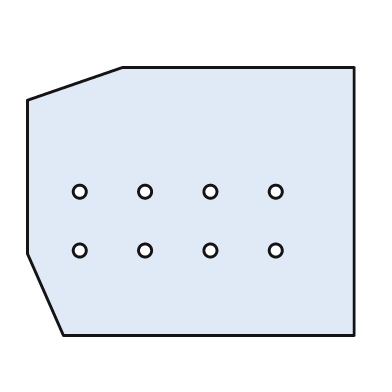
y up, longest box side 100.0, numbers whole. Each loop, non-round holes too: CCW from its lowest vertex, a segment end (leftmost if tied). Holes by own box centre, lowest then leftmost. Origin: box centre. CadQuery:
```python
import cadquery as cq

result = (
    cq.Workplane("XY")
    .moveTo(-39.0, -41.0)
    .lineTo(50.0, -41.0)
    .lineTo(50.0, 41.0)
    .lineTo(-21.0, 41.0)
    .lineTo(-50.0, 31.0)
    .lineTo(-50.0, -16.0)
    .close()
    .moveTo(-34.0, -15.0)
    .circle(2.0)
    .moveTo(-14.0, -15.0)
    .circle(2.0)
    .moveTo(6.0, -15.0)
    .circle(2.0)
    .moveTo(26.0, -15.0)
    .circle(2.0)
    .moveTo(-34.0, 3.0)
    .circle(2.0)
    .moveTo(-14.0, 3.0)
    .circle(2.0)
    .moveTo(6.0, 3.0)
    .circle(2.0)
    .moveTo(26.0, 3.0)
    .circle(2.0)
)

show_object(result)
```